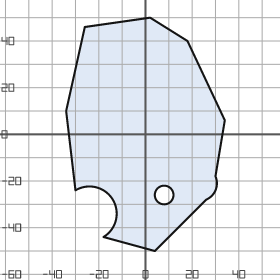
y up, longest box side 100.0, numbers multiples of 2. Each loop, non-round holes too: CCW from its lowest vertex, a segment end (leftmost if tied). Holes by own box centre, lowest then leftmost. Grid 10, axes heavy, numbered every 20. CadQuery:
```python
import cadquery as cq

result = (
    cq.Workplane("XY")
    .moveTo(4.0, -50.0)
    .lineTo(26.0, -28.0)
    .threePointArc((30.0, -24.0), (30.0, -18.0))
    .lineTo(34.0, 6.0)
    .lineTo(18.0, 40.0)
    .lineTo(2.0, 50.0)
    .lineTo(-26.0, 46.0)
    .lineTo(-34.0, 10.0)
    .lineTo(-30.0, -24.0)
    .threePointArc((-14.0, -28.0), (-18.0, -44.0))
    .close()
    .moveTo(8.0, -26.0)
    .circle(4.0)
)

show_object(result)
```